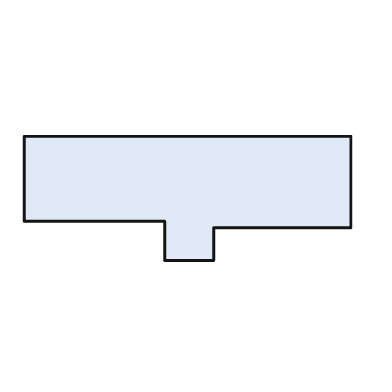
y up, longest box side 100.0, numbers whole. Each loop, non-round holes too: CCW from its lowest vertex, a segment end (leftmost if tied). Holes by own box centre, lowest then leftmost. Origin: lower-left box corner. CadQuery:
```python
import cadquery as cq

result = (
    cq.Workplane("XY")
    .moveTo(43.0, 0.0)
    .lineTo(58.0, 0.0)
    .lineTo(58.0, 10.0)
    .lineTo(100.0, 10.0)
    .lineTo(100.0, 38.0)
    .lineTo(0.0, 38.0)
    .lineTo(0.0, 12.0)
    .lineTo(43.0, 12.0)
    .close()
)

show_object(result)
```